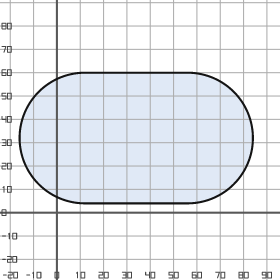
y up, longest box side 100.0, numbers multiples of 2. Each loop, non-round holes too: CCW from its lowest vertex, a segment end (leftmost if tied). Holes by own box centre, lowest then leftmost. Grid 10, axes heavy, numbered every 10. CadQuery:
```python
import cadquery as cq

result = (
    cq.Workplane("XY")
    .moveTo(12.0, 4.0)
    .lineTo(56.0, 4.0)
    .threePointArc((84.0, 32.0), (56.0, 60.0))
    .lineTo(12.0, 60.0)
    .threePointArc((-16.0, 32.0), (12.0, 4.0))
    .close()
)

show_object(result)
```